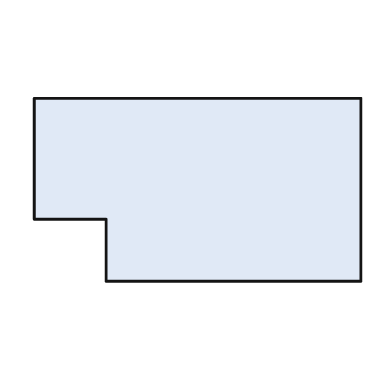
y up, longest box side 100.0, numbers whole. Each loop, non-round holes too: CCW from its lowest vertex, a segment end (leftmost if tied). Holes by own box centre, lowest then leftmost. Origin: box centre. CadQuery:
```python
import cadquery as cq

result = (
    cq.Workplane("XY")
    .moveTo(-28.0, -28.0)
    .lineTo(50.0, -28.0)
    .lineTo(50.0, 28.0)
    .lineTo(-50.0, 28.0)
    .lineTo(-50.0, -9.0)
    .lineTo(-28.0, -9.0)
    .close()
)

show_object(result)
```